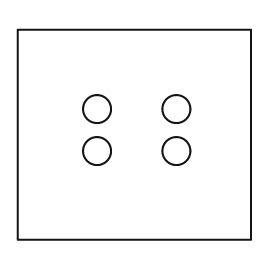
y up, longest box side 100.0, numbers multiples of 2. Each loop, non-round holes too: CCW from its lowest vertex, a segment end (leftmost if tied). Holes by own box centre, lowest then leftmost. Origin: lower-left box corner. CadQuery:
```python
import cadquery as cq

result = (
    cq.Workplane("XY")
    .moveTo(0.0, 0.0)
    .lineTo(100.0, 0.0)
    .lineTo(100.0, 90.0)
    .lineTo(0.0, 90.0)
    .close()
    .moveTo(34.0, 38.0)
    .circle(6.0)
    .moveTo(68.0, 38.0)
    .circle(6.0)
    .moveTo(34.0, 56.0)
    .circle(6.0)
    .moveTo(68.0, 56.0)
    .circle(6.0)
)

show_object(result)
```